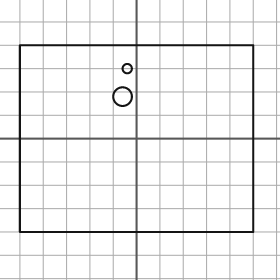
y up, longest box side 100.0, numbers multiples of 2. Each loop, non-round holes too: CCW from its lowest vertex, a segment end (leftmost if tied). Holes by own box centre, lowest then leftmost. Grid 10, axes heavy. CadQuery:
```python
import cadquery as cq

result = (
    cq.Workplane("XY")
    .moveTo(-50.0, -40.0)
    .lineTo(50.0, -40.0)
    .lineTo(50.0, 40.0)
    .lineTo(-50.0, 40.0)
    .close()
    .moveTo(-6.0, 18.0)
    .circle(4.0)
    .moveTo(-4.0, 30.0)
    .circle(2.0)
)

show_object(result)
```